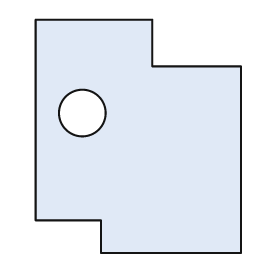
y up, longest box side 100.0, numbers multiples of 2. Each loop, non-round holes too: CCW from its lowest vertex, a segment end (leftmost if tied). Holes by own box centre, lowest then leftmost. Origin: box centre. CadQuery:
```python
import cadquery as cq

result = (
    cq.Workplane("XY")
    .moveTo(-16.0, -50.0)
    .lineTo(44.0, -50.0)
    .lineTo(44.0, 30.0)
    .lineTo(6.0, 30.0)
    .lineTo(6.0, 50.0)
    .lineTo(-44.0, 50.0)
    .lineTo(-44.0, -36.0)
    .lineTo(-16.0, -36.0)
    .close()
    .moveTo(-24.0, 10.0)
    .circle(10.0)
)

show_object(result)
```